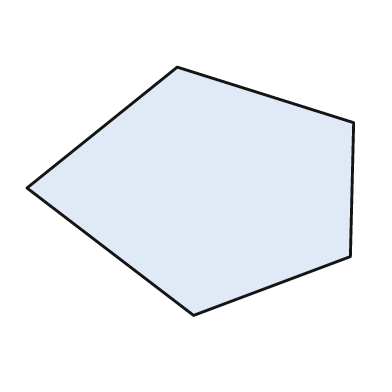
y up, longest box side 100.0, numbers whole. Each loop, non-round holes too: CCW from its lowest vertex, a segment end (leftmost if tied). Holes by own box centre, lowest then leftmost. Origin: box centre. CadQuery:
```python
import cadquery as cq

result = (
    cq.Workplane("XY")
    .moveTo(1.0, -38.0)
    .lineTo(49.0, -20.0)
    .lineTo(50.0, 21.0)
    .lineTo(-4.0, 38.0)
    .lineTo(-50.0, 1.0)
    .close()
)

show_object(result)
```